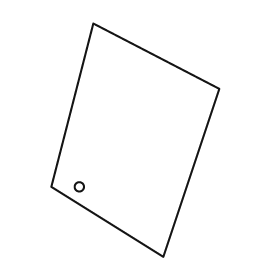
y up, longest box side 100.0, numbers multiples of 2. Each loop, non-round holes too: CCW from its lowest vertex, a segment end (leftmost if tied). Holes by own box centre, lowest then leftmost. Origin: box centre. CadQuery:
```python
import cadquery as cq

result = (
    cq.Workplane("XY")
    .moveTo(12.0, -50.0)
    .lineTo(36.0, 22.0)
    .lineTo(-18.0, 50.0)
    .lineTo(-36.0, -20.0)
    .close()
    .moveTo(-24.0, -20.0)
    .circle(2.0)
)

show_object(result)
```